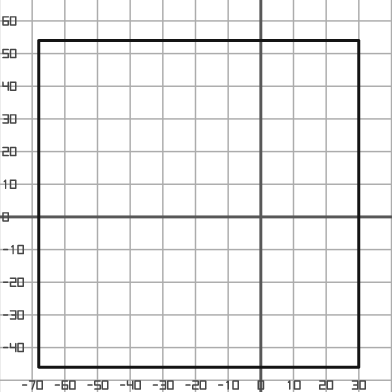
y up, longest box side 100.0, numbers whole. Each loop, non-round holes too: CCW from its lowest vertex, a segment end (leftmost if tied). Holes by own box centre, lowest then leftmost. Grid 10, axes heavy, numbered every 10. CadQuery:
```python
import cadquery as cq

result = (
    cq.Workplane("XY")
    .moveTo(-68.0, -46.0)
    .lineTo(30.0, -46.0)
    .lineTo(30.0, 54.0)
    .lineTo(-68.0, 54.0)
    .close()
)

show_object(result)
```